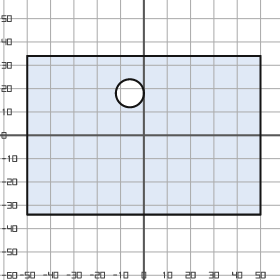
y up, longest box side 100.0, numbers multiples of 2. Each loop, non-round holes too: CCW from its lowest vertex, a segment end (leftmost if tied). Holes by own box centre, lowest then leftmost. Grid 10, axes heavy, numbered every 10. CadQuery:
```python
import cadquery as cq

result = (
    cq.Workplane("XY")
    .moveTo(-50.0, -34.0)
    .lineTo(50.0, -34.0)
    .lineTo(50.0, 34.0)
    .lineTo(-50.0, 34.0)
    .close()
    .moveTo(-6.0, 18.0)
    .circle(6.0)
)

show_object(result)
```